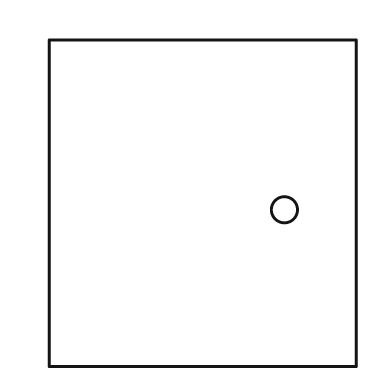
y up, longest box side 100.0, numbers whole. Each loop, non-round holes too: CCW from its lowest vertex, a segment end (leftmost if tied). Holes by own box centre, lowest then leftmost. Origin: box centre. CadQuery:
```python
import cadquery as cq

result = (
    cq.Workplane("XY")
    .moveTo(-47.0, -50.0)
    .lineTo(47.0, -50.0)
    .lineTo(47.0, 50.0)
    .lineTo(-47.0, 50.0)
    .close()
    .moveTo(25.0, -2.0)
    .circle(4.0)
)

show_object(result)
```